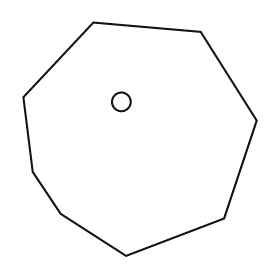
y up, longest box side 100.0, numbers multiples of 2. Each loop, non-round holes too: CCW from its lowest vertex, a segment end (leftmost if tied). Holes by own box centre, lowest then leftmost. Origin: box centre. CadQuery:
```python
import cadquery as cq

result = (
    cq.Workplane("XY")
    .moveTo(-6.0, -50.0)
    .lineTo(36.0, -34.0)
    .lineTo(50.0, 8.0)
    .lineTo(26.0, 46.0)
    .lineTo(-20.0, 50.0)
    .lineTo(-50.0, 18.0)
    .lineTo(-46.0, -14.0)
    .lineTo(-34.0, -32.0)
    .close()
    .moveTo(-8.0, 16.0)
    .circle(4.0)
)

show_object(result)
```